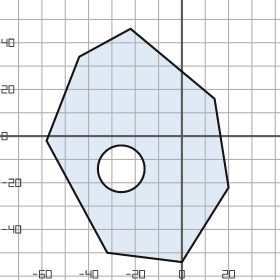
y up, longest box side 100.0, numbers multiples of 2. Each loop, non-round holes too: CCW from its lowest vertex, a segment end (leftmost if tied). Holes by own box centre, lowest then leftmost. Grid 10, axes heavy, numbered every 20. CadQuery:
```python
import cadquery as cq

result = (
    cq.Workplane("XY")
    .moveTo(0.0, -54.0)
    .lineTo(20.0, -22.0)
    .lineTo(14.0, 16.0)
    .lineTo(-22.0, 46.0)
    .lineTo(-44.0, 34.0)
    .lineTo(-58.0, -2.0)
    .lineTo(-32.0, -50.0)
    .close()
    .moveTo(-26.0, -14.0)
    .circle(10.0)
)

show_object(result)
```